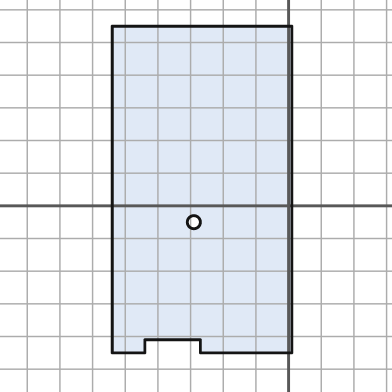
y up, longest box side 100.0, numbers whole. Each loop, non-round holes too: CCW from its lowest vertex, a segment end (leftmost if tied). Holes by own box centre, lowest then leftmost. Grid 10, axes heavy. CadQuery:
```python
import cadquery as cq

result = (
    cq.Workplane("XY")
    .moveTo(-54.0, -45.0)
    .lineTo(-44.0, -45.0)
    .lineTo(-44.0, -41.0)
    .lineTo(-27.0, -41.0)
    .lineTo(-27.0, -45.0)
    .lineTo(1.0, -45.0)
    .lineTo(1.0, 55.0)
    .lineTo(-54.0, 55.0)
    .close()
    .moveTo(-29.0, -5.0)
    .circle(2.0)
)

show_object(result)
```